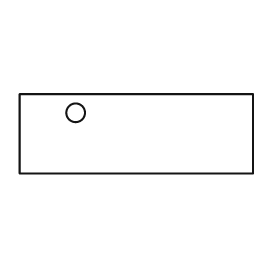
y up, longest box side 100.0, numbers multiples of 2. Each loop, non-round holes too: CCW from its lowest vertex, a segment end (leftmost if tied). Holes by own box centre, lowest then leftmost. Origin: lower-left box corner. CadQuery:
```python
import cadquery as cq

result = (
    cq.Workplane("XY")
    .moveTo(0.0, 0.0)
    .lineTo(100.0, 0.0)
    .lineTo(100.0, 34.0)
    .lineTo(0.0, 34.0)
    .close()
    .moveTo(24.0, 26.0)
    .circle(4.0)
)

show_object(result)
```